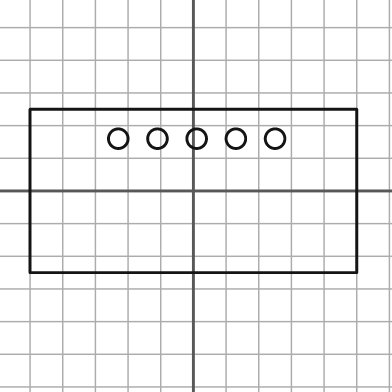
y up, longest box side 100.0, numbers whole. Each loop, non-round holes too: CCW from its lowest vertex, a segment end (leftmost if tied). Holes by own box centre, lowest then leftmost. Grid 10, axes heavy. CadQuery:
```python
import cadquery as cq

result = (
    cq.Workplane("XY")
    .moveTo(-50.0, -25.0)
    .lineTo(50.0, -25.0)
    .lineTo(50.0, 25.0)
    .lineTo(-50.0, 25.0)
    .close()
    .moveTo(-23.0, 16.0)
    .circle(3.0)
    .moveTo(-11.0, 16.0)
    .circle(3.0)
    .moveTo(1.0, 16.0)
    .circle(3.0)
    .moveTo(13.0, 16.0)
    .circle(3.0)
    .moveTo(25.0, 16.0)
    .circle(3.0)
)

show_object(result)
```